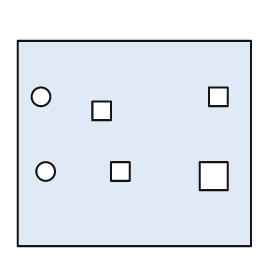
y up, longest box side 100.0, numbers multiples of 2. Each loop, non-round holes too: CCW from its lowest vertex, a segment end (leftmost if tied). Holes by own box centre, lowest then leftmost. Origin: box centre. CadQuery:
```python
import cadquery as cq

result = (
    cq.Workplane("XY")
    .moveTo(-50.0, -44.0)
    .lineTo(50.0, -44.0)
    .lineTo(50.0, 44.0)
    .lineTo(-50.0, 44.0)
    .close()
    .moveTo(28.0, -20.0)
    .lineTo(40.0, -20.0)
    .lineTo(40.0, -8.0)
    .lineTo(28.0, -8.0)
    .close()
    .moveTo(-38.0, -12.0)
    .circle(4.0)
    .moveTo(-10.0, -16.0)
    .lineTo(-2.0, -16.0)
    .lineTo(-2.0, -8.0)
    .lineTo(-10.0, -8.0)
    .close()
    .moveTo(-18.0, 10.0)
    .lineTo(-10.0, 10.0)
    .lineTo(-10.0, 18.0)
    .lineTo(-18.0, 18.0)
    .close()
    .moveTo(-40.0, 20.0)
    .circle(4.0)
    .moveTo(32.0, 16.0)
    .lineTo(40.0, 16.0)
    .lineTo(40.0, 24.0)
    .lineTo(32.0, 24.0)
    .close()
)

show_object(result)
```